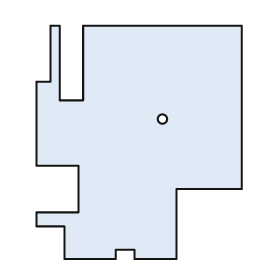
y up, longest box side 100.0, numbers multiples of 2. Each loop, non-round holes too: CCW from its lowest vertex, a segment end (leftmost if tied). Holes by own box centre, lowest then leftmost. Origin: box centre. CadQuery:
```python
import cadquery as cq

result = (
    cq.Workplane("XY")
    .moveTo(-32.0, -50.0)
    .lineTo(-10.0, -50.0)
    .lineTo(-10.0, -46.0)
    .lineTo(-2.0, -46.0)
    .lineTo(-2.0, -50.0)
    .lineTo(16.0, -50.0)
    .lineTo(16.0, -20.0)
    .lineTo(44.0, -20.0)
    .lineTo(44.0, 50.0)
    .lineTo(-24.0, 50.0)
    .lineTo(-24.0, 18.0)
    .lineTo(-34.0, 18.0)
    .lineTo(-34.0, 50.0)
    .lineTo(-38.0, 50.0)
    .lineTo(-38.0, 26.0)
    .lineTo(-44.0, 26.0)
    .lineTo(-44.0, -10.0)
    .lineTo(-26.0, -10.0)
    .lineTo(-26.0, -30.0)
    .lineTo(-44.0, -30.0)
    .lineTo(-44.0, -36.0)
    .lineTo(-32.0, -36.0)
    .close()
    .moveTo(10.0, 10.0)
    .circle(2.0)
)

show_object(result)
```